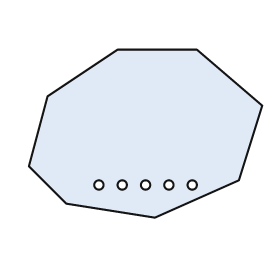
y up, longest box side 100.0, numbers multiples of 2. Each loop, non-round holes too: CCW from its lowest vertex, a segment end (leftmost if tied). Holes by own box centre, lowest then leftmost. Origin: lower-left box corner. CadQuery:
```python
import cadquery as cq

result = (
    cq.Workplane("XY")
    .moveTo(54.0, 0.0)
    .lineTo(90.0, 16.0)
    .lineTo(100.0, 48.0)
    .lineTo(72.0, 72.0)
    .lineTo(38.0, 72.0)
    .lineTo(8.0, 52.0)
    .lineTo(0.0, 22.0)
    .lineTo(16.0, 6.0)
    .close()
    .moveTo(30.0, 14.0)
    .circle(2.0)
    .moveTo(40.0, 14.0)
    .circle(2.0)
    .moveTo(50.0, 14.0)
    .circle(2.0)
    .moveTo(60.0, 14.0)
    .circle(2.0)
    .moveTo(70.0, 14.0)
    .circle(2.0)
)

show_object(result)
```